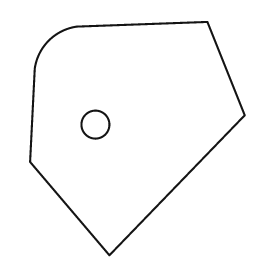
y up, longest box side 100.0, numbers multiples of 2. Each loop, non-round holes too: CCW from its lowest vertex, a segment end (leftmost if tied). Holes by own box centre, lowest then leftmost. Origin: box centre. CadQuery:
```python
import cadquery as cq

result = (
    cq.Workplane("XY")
    .moveTo(-12.0, -50.0)
    .lineTo(46.0, 10.0)
    .lineTo(30.0, 50.0)
    .lineTo(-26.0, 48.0)
    .threePointArc((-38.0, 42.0), (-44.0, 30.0))
    .lineTo(-46.0, -10.0)
    .close()
    .moveTo(-18.0, 6.0)
    .circle(6.0)
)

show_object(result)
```